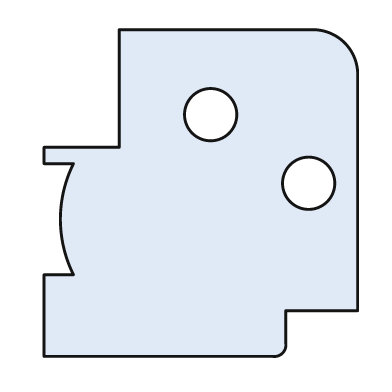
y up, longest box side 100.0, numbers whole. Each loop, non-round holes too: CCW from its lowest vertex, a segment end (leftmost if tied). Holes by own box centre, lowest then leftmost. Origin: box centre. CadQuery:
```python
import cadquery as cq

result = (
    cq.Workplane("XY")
    .moveTo(-48.0, -50.0)
    .lineTo(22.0, -50.0)
    .threePointArc((25.0, -49.0), (26.0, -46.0))
    .lineTo(26.0, -36.0)
    .lineTo(48.0, -36.0)
    .lineTo(48.0, 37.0)
    .threePointArc((44.0, 46.0), (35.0, 50.0))
    .lineTo(-25.0, 50.0)
    .lineTo(-25.0, 14.0)
    .lineTo(-48.0, 14.0)
    .lineTo(-48.0, 9.0)
    .lineTo(-39.0, 9.0)
    .threePointArc((-43.0, -8.0), (-39.0, -25.0))
    .lineTo(-48.0, -25.0)
    .close()
    .moveTo(33.0, 3.0)
    .circle(8.0)
    .moveTo(3.0, 24.0)
    .circle(8.0)
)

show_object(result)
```